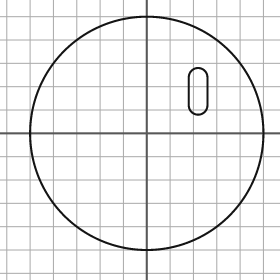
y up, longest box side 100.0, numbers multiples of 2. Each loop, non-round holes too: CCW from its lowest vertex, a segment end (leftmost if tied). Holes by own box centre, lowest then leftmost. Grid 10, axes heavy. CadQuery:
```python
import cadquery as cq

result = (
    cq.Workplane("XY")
    .moveTo(0.0, 0.0)
    .circle(50.0)
    .moveTo(18.0, 12.0)
    .threePointArc((22.0, 8.0), (26.0, 12.0))
    .lineTo(26.0, 24.0)
    .threePointArc((22.0, 28.0), (18.0, 24.0))
    .close()
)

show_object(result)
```